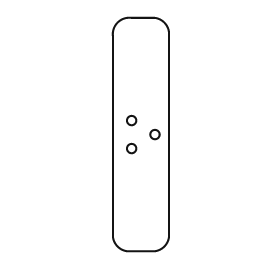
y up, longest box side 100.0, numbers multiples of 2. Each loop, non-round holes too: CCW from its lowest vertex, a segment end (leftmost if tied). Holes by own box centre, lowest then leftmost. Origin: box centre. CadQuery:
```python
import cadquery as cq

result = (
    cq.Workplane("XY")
    .moveTo(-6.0, -50.0)
    .lineTo(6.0, -50.0)
    .threePointArc((10.0, -48.0), (12.0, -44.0))
    .lineTo(12.0, 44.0)
    .threePointArc((10.0, 48.0), (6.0, 50.0))
    .lineTo(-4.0, 50.0)
    .threePointArc((-10.0, 48.0), (-12.0, 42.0))
    .lineTo(-12.0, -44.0)
    .threePointArc((-10.0, -48.0), (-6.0, -50.0))
    .close()
    .moveTo(-4.0, -6.0)
    .circle(2.0)
    .moveTo(6.0, 0.0)
    .circle(2.0)
    .moveTo(-4.0, 6.0)
    .circle(2.0)
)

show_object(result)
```